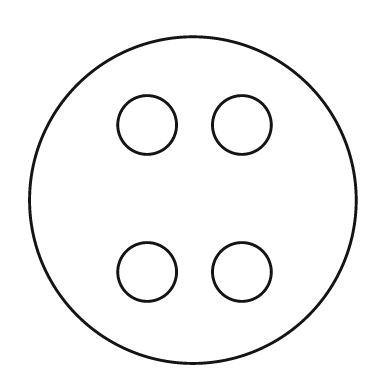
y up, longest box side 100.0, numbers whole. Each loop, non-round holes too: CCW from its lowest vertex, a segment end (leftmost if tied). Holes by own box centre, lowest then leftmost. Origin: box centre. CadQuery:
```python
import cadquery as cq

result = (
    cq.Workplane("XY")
    .moveTo(0.0, 0.0)
    .circle(50.0)
    .moveTo(-14.0, -22.0)
    .circle(9.0)
    .moveTo(15.0, -22.0)
    .circle(9.0)
    .moveTo(-14.0, 23.0)
    .circle(9.0)
    .moveTo(15.0, 23.0)
    .circle(9.0)
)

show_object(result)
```